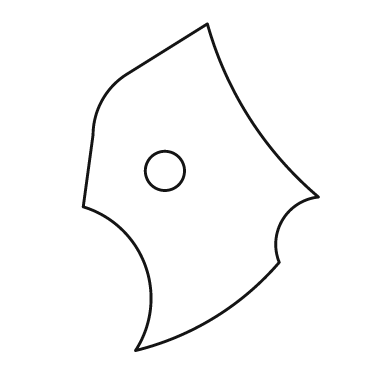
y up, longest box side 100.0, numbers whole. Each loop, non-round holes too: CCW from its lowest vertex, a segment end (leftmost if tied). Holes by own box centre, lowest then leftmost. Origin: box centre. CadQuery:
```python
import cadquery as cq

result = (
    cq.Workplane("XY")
    .moveTo(-20.0, -50.0)
    .threePointArc((4.0, -40.0), (24.0, -23.0))
    .threePointArc((25.0, -10.0), (36.0, -3.0))
    .threePointArc((15.0, 21.0), (2.0, 50.0))
    .lineTo(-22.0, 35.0)
    .threePointArc((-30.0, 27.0), (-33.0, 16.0))
    .lineTo(-36.0, -6.0)
    .threePointArc((-17.0, -24.0), (-20.0, -50.0))
    .close()
    .moveTo(-11.0, 5.0)
    .circle(6.0)
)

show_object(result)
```